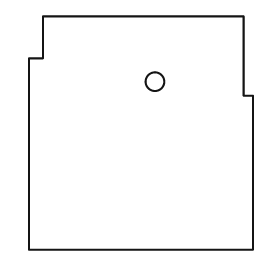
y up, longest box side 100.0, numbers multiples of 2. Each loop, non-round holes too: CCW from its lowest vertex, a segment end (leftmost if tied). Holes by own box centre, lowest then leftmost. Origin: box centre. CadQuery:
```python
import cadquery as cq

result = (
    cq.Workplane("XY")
    .moveTo(-48.0, -50.0)
    .lineTo(48.0, -50.0)
    .lineTo(48.0, 16.0)
    .lineTo(44.0, 16.0)
    .lineTo(44.0, 50.0)
    .lineTo(-42.0, 50.0)
    .lineTo(-42.0, 32.0)
    .lineTo(-48.0, 32.0)
    .close()
    .moveTo(6.0, 22.0)
    .circle(4.0)
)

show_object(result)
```